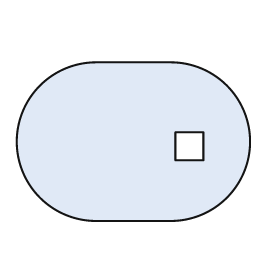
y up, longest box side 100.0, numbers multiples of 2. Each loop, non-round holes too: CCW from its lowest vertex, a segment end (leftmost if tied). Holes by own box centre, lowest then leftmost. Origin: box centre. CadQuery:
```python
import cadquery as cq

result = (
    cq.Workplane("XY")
    .moveTo(-16.0, -34.0)
    .lineTo(16.0, -34.0)
    .threePointArc((50.0, 0.0), (16.0, 34.0))
    .lineTo(-16.0, 34.0)
    .threePointArc((-50.0, 0.0), (-16.0, -34.0))
    .close()
    .moveTo(18.0, -8.0)
    .lineTo(30.0, -8.0)
    .lineTo(30.0, 4.0)
    .lineTo(18.0, 4.0)
    .close()
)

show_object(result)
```